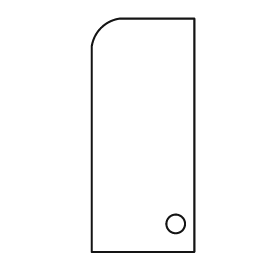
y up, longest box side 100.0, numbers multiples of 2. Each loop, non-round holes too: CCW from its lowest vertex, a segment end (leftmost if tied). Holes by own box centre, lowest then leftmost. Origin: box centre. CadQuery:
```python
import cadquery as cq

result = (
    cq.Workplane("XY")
    .moveTo(-22.0, -50.0)
    .lineTo(22.0, -50.0)
    .lineTo(22.0, 50.0)
    .lineTo(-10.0, 50.0)
    .threePointArc((-18.0, 46.0), (-22.0, 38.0))
    .close()
    .moveTo(14.0, -38.0)
    .circle(4.0)
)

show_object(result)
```